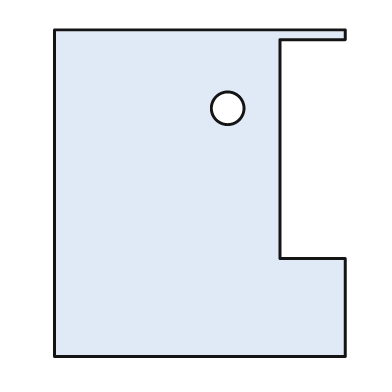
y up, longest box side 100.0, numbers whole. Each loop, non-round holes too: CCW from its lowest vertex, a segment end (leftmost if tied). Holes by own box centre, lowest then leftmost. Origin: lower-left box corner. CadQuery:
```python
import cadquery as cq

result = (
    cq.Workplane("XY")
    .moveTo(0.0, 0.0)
    .lineTo(89.0, 0.0)
    .lineTo(89.0, 30.0)
    .lineTo(69.0, 30.0)
    .lineTo(69.0, 97.0)
    .lineTo(89.0, 97.0)
    .lineTo(89.0, 100.0)
    .lineTo(0.0, 100.0)
    .close()
    .moveTo(53.0, 76.0)
    .circle(5.0)
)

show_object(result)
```